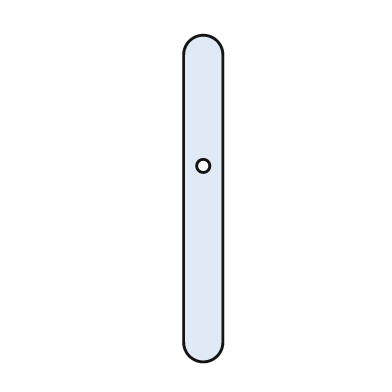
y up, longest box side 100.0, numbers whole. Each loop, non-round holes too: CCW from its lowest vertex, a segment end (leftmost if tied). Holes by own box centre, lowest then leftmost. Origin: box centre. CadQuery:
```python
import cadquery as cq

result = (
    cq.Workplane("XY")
    .moveTo(-6.0, -44.0)
    .threePointArc((0.0, -50.0), (6.0, -44.0))
    .lineTo(6.0, 44.0)
    .threePointArc((0.0, 50.0), (-6.0, 44.0))
    .close()
    .moveTo(0.0, 10.0)
    .circle(2.0)
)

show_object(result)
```